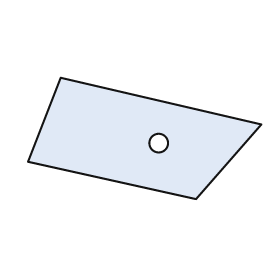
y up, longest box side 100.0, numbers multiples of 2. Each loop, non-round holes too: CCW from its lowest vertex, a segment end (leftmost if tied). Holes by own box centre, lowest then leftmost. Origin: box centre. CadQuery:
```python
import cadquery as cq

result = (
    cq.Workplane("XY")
    .moveTo(22.0, -26.0)
    .lineTo(50.0, 6.0)
    .lineTo(-36.0, 26.0)
    .lineTo(-50.0, -10.0)
    .close()
    .moveTo(6.0, -2.0)
    .circle(4.0)
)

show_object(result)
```